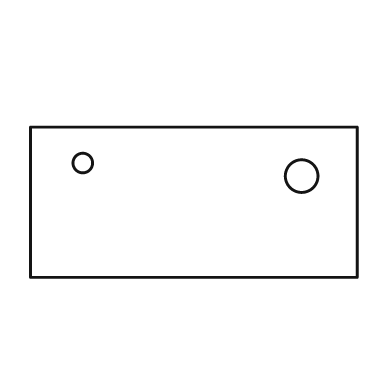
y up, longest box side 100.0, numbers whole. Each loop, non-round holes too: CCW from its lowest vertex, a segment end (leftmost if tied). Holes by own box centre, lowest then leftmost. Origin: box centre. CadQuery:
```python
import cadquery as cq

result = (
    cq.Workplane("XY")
    .moveTo(-50.0, -23.0)
    .lineTo(50.0, -23.0)
    .lineTo(50.0, 23.0)
    .lineTo(-50.0, 23.0)
    .close()
    .moveTo(33.0, 8.0)
    .circle(5.0)
    .moveTo(-34.0, 12.0)
    .circle(3.0)
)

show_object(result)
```